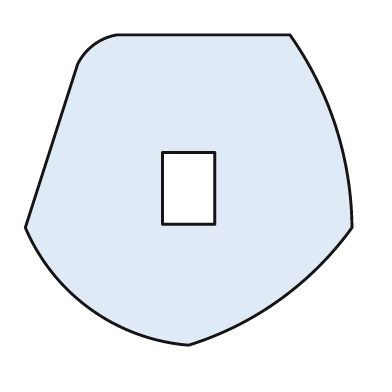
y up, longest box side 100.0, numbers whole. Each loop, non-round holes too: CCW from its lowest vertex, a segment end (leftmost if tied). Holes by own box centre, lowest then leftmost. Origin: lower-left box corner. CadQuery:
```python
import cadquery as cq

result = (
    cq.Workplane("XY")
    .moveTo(50.0, 0.0)
    .threePointArc((78.0, 14.0), (100.0, 36.0))
    .threePointArc((95.0, 67.0), (81.0, 95.0))
    .lineTo(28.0, 95.0)
    .threePointArc((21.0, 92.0), (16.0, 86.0))
    .lineTo(0.0, 36.0)
    .threePointArc((20.0, 11.0), (50.0, 0.0))
    .close()
    .moveTo(42.0, 37.0)
    .lineTo(58.0, 37.0)
    .lineTo(58.0, 59.0)
    .lineTo(42.0, 59.0)
    .close()
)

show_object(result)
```